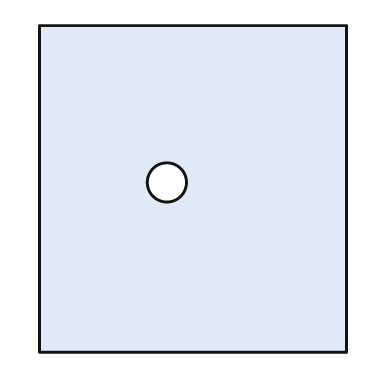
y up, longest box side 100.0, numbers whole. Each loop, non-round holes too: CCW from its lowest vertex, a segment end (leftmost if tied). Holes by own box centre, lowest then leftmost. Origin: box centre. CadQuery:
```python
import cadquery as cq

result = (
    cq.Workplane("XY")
    .moveTo(-47.0, -50.0)
    .lineTo(47.0, -50.0)
    .lineTo(47.0, 50.0)
    .lineTo(-47.0, 50.0)
    .close()
    .moveTo(-8.0, 2.0)
    .circle(6.0)
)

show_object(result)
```